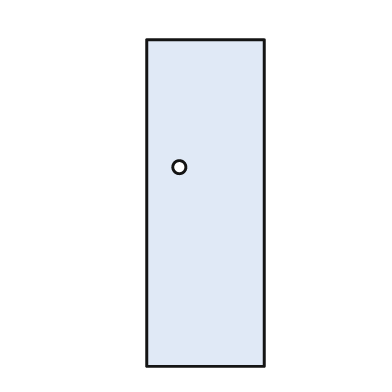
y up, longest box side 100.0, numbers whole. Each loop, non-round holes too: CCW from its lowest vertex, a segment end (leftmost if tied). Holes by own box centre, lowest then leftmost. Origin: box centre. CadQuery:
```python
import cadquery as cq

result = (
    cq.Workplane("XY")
    .moveTo(-18.0, -50.0)
    .lineTo(18.0, -50.0)
    .lineTo(18.0, 50.0)
    .lineTo(-18.0, 50.0)
    .close()
    .moveTo(-8.0, 11.0)
    .circle(2.0)
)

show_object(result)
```